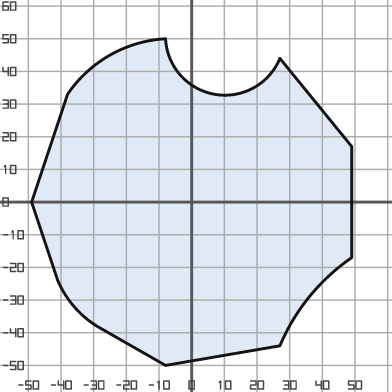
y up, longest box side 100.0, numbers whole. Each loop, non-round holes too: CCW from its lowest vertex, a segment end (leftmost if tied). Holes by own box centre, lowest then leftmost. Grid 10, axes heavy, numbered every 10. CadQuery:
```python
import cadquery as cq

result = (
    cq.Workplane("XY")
    .moveTo(-8.0, -50.0)
    .lineTo(27.0, -44.0)
    .threePointArc((36.0, -29.0), (49.0, -17.0))
    .lineTo(49.0, 17.0)
    .lineTo(27.0, 44.0)
    .threePointArc((7.0, 33.0), (-8.0, 50.0))
    .threePointArc((-25.0, 45.0), (-38.0, 33.0))
    .lineTo(-49.0, 0.0)
    .lineTo(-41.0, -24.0)
    .threePointArc((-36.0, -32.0), (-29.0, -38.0))
    .close()
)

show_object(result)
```